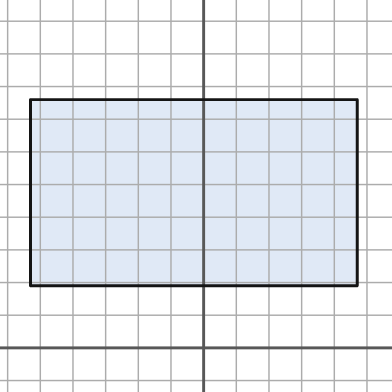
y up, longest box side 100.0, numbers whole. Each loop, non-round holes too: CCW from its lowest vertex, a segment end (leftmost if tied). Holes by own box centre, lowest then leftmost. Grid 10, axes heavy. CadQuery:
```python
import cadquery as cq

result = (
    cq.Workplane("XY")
    .moveTo(-53.0, 19.0)
    .lineTo(47.0, 19.0)
    .lineTo(47.0, 76.0)
    .lineTo(-53.0, 76.0)
    .close()
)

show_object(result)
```